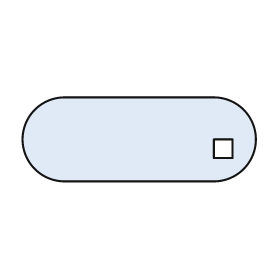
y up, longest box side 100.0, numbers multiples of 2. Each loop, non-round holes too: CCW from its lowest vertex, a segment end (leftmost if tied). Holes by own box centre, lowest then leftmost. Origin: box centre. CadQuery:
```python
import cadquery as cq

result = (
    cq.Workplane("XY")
    .moveTo(-32.0, -18.0)
    .lineTo(32.0, -18.0)
    .threePointArc((50.0, 0.0), (32.0, 18.0))
    .lineTo(-32.0, 18.0)
    .threePointArc((-50.0, 0.0), (-32.0, -18.0))
    .close()
    .moveTo(32.0, -8.0)
    .lineTo(40.0, -8.0)
    .lineTo(40.0, 0.0)
    .lineTo(32.0, 0.0)
    .close()
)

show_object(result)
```